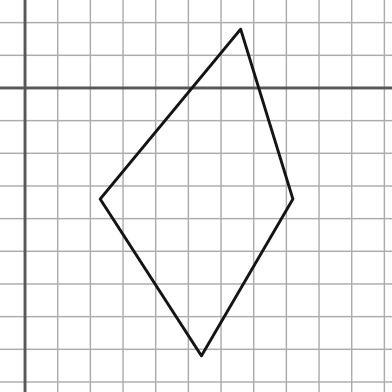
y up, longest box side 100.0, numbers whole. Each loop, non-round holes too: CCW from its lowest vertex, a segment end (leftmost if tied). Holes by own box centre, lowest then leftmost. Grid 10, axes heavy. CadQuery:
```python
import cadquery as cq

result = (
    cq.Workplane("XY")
    .moveTo(54.0, -82.0)
    .lineTo(82.0, -34.0)
    .lineTo(66.0, 18.0)
    .lineTo(23.0, -34.0)
    .close()
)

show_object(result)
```